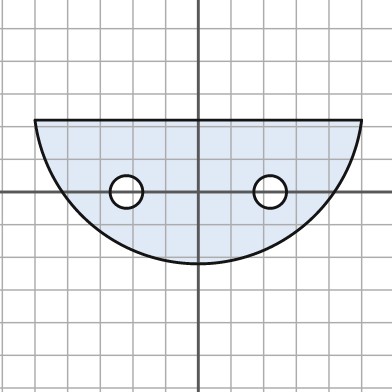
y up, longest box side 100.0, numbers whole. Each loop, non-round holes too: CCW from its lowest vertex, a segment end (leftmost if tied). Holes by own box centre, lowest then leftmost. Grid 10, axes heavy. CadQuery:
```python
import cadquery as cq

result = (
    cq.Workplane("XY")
    .moveTo(-50.0, 22.0)
    .threePointArc((0.0, -22.0), (50.0, 22.0))
    .close()
    .moveTo(-22.0, 0.0)
    .circle(5.0)
    .moveTo(22.0, 0.0)
    .circle(5.0)
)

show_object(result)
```